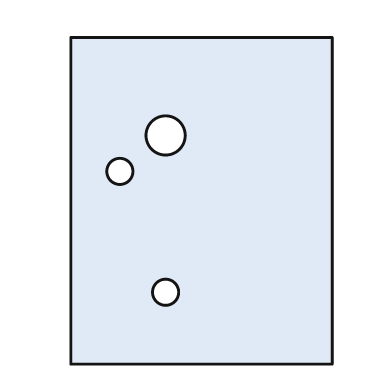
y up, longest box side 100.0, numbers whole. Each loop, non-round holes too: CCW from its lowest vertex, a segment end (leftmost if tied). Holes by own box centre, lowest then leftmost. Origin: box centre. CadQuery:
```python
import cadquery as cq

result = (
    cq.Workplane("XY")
    .moveTo(-40.0, -50.0)
    .lineTo(40.0, -50.0)
    .lineTo(40.0, 50.0)
    .lineTo(-40.0, 50.0)
    .close()
    .moveTo(-11.0, -28.0)
    .circle(4.0)
    .moveTo(-25.0, 9.0)
    .circle(4.0)
    .moveTo(-11.0, 20.0)
    .circle(6.0)
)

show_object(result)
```